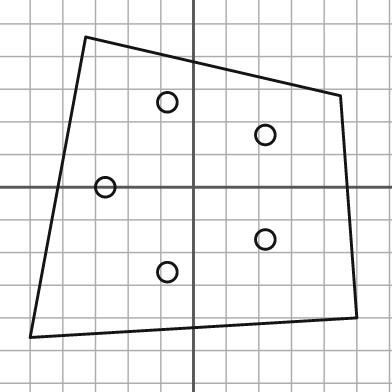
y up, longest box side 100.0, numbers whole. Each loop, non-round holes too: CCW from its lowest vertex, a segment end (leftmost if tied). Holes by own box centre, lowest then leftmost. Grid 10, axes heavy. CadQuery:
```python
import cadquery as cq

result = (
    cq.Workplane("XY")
    .moveTo(-50.0, -46.0)
    .lineTo(50.0, -40.0)
    .lineTo(45.0, 28.0)
    .lineTo(-33.0, 46.0)
    .close()
    .moveTo(-8.0, -26.0)
    .circle(3.0)
    .moveTo(22.0, -16.0)
    .circle(3.0)
    .moveTo(-27.0, 0.0)
    .circle(3.0)
    .moveTo(22.0, 16.0)
    .circle(3.0)
    .moveTo(-8.0, 26.0)
    .circle(3.0)
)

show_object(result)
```